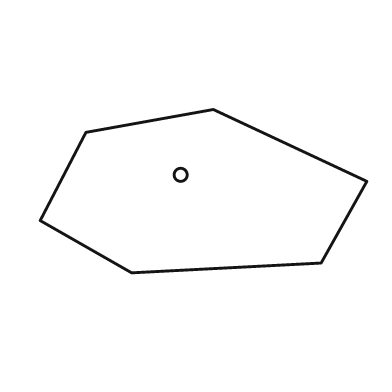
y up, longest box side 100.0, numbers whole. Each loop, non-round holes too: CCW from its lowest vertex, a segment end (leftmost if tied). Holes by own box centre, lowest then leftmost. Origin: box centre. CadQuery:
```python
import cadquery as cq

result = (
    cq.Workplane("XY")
    .moveTo(-22.0, -25.0)
    .lineTo(36.0, -22.0)
    .lineTo(50.0, 3.0)
    .lineTo(3.0, 25.0)
    .lineTo(-36.0, 18.0)
    .lineTo(-50.0, -9.0)
    .close()
    .moveTo(-7.0, 5.0)
    .circle(2.0)
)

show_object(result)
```